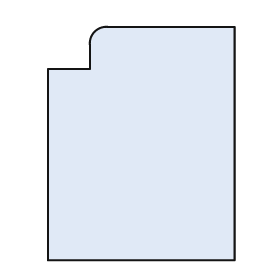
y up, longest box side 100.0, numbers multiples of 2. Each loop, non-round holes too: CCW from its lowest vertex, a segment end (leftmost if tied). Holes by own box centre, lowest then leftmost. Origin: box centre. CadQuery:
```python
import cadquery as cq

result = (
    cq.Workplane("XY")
    .moveTo(-40.0, -50.0)
    .lineTo(40.0, -50.0)
    .lineTo(40.0, 50.0)
    .lineTo(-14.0, 50.0)
    .threePointArc((-20.0, 48.0), (-22.0, 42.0))
    .lineTo(-22.0, 32.0)
    .lineTo(-40.0, 32.0)
    .close()
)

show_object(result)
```